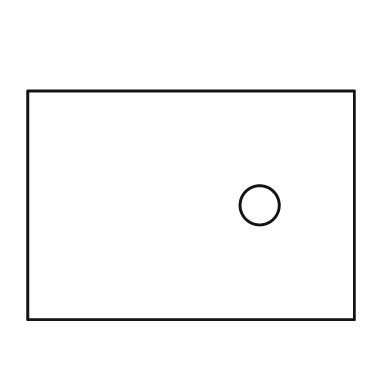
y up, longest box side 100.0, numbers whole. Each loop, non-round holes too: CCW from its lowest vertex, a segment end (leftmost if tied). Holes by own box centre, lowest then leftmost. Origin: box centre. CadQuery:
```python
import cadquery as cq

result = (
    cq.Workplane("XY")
    .moveTo(-50.0, -35.0)
    .lineTo(50.0, -35.0)
    .lineTo(50.0, 35.0)
    .lineTo(-50.0, 35.0)
    .close()
    .moveTo(21.0, 0.0)
    .circle(6.0)
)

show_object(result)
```